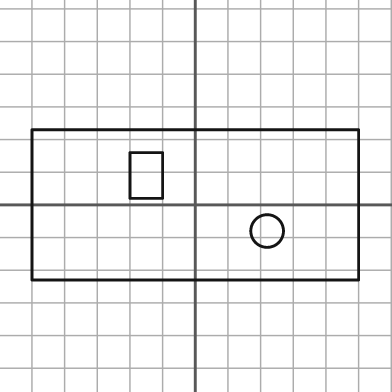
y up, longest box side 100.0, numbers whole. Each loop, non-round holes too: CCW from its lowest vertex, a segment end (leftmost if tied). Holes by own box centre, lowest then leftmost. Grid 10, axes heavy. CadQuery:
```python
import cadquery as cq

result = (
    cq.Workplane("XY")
    .moveTo(-50.0, -23.0)
    .lineTo(50.0, -23.0)
    .lineTo(50.0, 23.0)
    .lineTo(-50.0, 23.0)
    .close()
    .moveTo(22.0, -8.0)
    .circle(5.0)
    .moveTo(-20.0, 2.0)
    .lineTo(-10.0, 2.0)
    .lineTo(-10.0, 16.0)
    .lineTo(-20.0, 16.0)
    .close()
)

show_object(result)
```